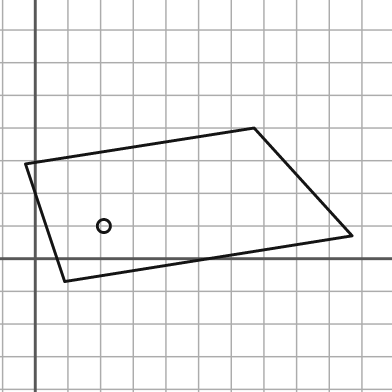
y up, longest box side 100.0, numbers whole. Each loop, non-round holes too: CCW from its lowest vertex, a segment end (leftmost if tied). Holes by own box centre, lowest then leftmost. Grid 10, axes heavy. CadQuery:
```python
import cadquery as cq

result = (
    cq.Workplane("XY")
    .moveTo(9.0, -7.0)
    .lineTo(97.0, 7.0)
    .lineTo(67.0, 40.0)
    .lineTo(-3.0, 29.0)
    .close()
    .moveTo(21.0, 10.0)
    .circle(2.0)
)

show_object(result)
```